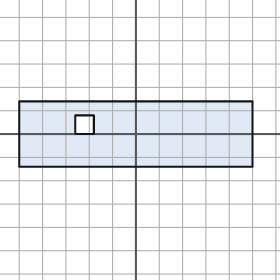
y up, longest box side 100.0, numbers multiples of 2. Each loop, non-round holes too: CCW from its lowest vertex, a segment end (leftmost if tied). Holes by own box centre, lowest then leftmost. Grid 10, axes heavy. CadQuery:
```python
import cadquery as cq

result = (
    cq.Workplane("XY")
    .moveTo(-50.0, -14.0)
    .lineTo(50.0, -14.0)
    .lineTo(50.0, 14.0)
    .lineTo(-50.0, 14.0)
    .close()
    .moveTo(-26.0, 0.0)
    .lineTo(-18.0, 0.0)
    .lineTo(-18.0, 8.0)
    .lineTo(-26.0, 8.0)
    .close()
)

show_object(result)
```